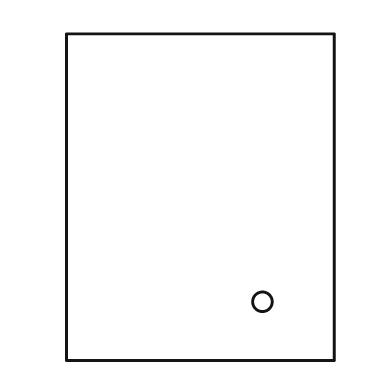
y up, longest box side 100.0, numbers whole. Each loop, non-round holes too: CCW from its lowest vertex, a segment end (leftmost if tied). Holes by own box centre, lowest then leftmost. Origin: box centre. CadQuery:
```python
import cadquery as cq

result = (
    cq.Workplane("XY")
    .moveTo(-41.0, -50.0)
    .lineTo(41.0, -50.0)
    .lineTo(41.0, 50.0)
    .lineTo(-41.0, 50.0)
    .close()
    .moveTo(19.0, -32.0)
    .circle(3.0)
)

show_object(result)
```